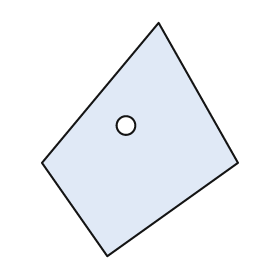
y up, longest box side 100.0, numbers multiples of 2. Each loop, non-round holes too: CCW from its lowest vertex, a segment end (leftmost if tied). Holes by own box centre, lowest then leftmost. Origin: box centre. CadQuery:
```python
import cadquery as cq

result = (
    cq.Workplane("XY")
    .moveTo(-14.0, -50.0)
    .lineTo(42.0, -10.0)
    .lineTo(8.0, 50.0)
    .lineTo(-42.0, -10.0)
    .close()
    .moveTo(-6.0, 6.0)
    .circle(4.0)
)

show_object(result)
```